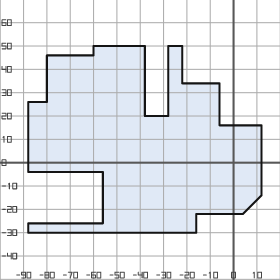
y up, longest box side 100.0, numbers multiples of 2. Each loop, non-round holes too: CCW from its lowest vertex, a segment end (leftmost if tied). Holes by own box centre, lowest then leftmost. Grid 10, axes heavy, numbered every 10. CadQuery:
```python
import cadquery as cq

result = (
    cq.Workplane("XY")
    .moveTo(-88.0, -30.0)
    .lineTo(-16.0, -30.0)
    .lineTo(-16.0, -22.0)
    .lineTo(4.0, -22.0)
    .lineTo(12.0, -14.0)
    .lineTo(12.0, 16.0)
    .lineTo(-6.0, 16.0)
    .lineTo(-6.0, 34.0)
    .lineTo(-22.0, 34.0)
    .lineTo(-22.0, 50.0)
    .lineTo(-28.0, 50.0)
    .lineTo(-28.0, 20.0)
    .lineTo(-38.0, 20.0)
    .lineTo(-38.0, 50.0)
    .lineTo(-60.0, 50.0)
    .lineTo(-60.0, 46.0)
    .lineTo(-80.0, 46.0)
    .lineTo(-80.0, 26.0)
    .lineTo(-88.0, 26.0)
    .lineTo(-88.0, -4.0)
    .lineTo(-56.0, -4.0)
    .lineTo(-56.0, -26.0)
    .lineTo(-88.0, -26.0)
    .close()
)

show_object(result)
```